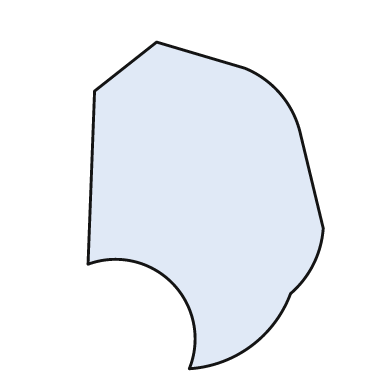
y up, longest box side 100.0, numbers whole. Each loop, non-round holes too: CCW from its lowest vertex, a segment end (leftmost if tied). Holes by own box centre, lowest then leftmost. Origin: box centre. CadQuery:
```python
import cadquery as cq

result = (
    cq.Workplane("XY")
    .moveTo(-5.0, -50.0)
    .threePointArc((14.0, -43.0), (26.0, -27.0))
    .threePointArc((33.0, -18.0), (36.0, -7.0))
    .lineTo(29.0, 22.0)
    .threePointArc((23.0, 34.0), (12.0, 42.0))
    .lineTo(-15.0, 50.0)
    .lineTo(-34.0, 35.0)
    .lineTo(-36.0, -18.0)
    .threePointArc((-10.0, -24.0), (-5.0, -50.0))
    .close()
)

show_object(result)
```